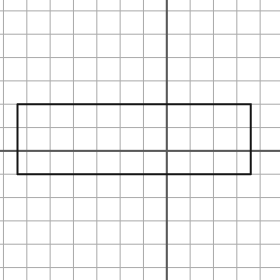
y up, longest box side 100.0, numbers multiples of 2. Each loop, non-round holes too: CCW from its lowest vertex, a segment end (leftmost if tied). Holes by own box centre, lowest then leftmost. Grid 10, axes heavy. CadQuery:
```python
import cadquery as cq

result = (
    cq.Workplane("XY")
    .moveTo(-64.0, -10.0)
    .lineTo(36.0, -10.0)
    .lineTo(36.0, 20.0)
    .lineTo(-64.0, 20.0)
    .close()
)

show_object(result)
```